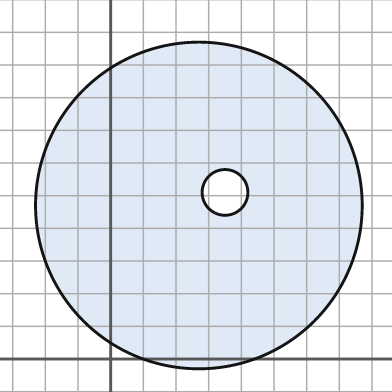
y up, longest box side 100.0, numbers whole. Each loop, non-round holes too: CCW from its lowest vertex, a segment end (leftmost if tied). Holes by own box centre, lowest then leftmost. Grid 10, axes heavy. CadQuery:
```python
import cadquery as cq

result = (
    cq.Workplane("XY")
    .moveTo(27.0, 47.0)
    .circle(50.0)
    .moveTo(35.0, 51.0)
    .circle(7.0)
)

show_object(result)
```